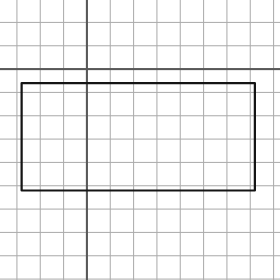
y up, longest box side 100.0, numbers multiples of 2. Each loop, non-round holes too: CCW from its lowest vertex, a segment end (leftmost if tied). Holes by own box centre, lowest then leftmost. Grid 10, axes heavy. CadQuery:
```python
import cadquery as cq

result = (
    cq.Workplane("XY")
    .moveTo(-28.0, -52.0)
    .lineTo(72.0, -52.0)
    .lineTo(72.0, -6.0)
    .lineTo(-28.0, -6.0)
    .close()
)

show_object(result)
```